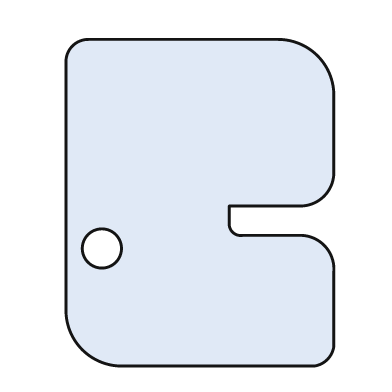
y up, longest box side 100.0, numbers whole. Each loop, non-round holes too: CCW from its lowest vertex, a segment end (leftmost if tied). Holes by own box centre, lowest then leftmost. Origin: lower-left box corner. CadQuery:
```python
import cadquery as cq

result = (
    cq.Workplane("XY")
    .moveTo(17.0, 0.0)
    .lineTo(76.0, 0.0)
    .threePointArc((80.0, 2.0), (82.0, 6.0))
    .lineTo(82.0, 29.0)
    .threePointArc((79.0, 37.0), (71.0, 40.0))
    .lineTo(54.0, 40.0)
    .threePointArc((51.0, 41.0), (50.0, 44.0))
    .lineTo(50.0, 49.0)
    .lineTo(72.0, 49.0)
    .threePointArc((79.0, 52.0), (82.0, 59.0))
    .lineTo(82.0, 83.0)
    .threePointArc((77.0, 95.0), (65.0, 100.0))
    .lineTo(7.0, 100.0)
    .threePointArc((2.0, 98.0), (0.0, 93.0))
    .lineTo(0.0, 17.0)
    .threePointArc((5.0, 5.0), (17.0, 0.0))
    .close()
    .moveTo(11.0, 36.0)
    .circle(6.0)
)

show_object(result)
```